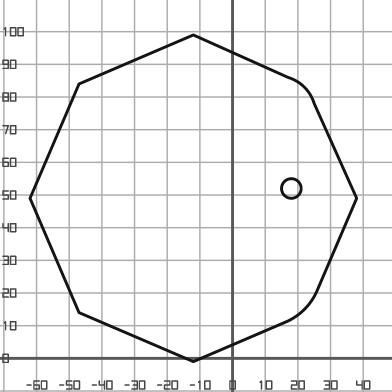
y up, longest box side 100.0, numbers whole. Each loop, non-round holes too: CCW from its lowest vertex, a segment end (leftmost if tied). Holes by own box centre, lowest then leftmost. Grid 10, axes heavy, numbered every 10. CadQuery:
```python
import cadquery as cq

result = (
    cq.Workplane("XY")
    .moveTo(-12.0, -1.0)
    .lineTo(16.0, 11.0)
    .threePointArc((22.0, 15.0), (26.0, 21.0))
    .lineTo(38.0, 49.0)
    .lineTo(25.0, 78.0)
    .threePointArc((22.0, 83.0), (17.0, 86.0))
    .lineTo(-12.0, 99.0)
    .lineTo(-47.0, 84.0)
    .lineTo(-62.0, 49.0)
    .lineTo(-47.0, 14.0)
    .close()
    .moveTo(18.0, 52.0)
    .circle(3.0)
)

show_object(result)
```